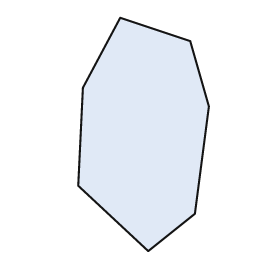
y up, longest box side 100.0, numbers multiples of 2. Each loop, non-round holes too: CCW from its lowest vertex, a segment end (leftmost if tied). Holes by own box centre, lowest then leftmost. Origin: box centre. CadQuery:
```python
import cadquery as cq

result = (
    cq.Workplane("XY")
    .moveTo(2.0, -50.0)
    .lineTo(22.0, -34.0)
    .lineTo(28.0, 12.0)
    .lineTo(20.0, 40.0)
    .lineTo(-10.0, 50.0)
    .lineTo(-26.0, 20.0)
    .lineTo(-28.0, -22.0)
    .close()
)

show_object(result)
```